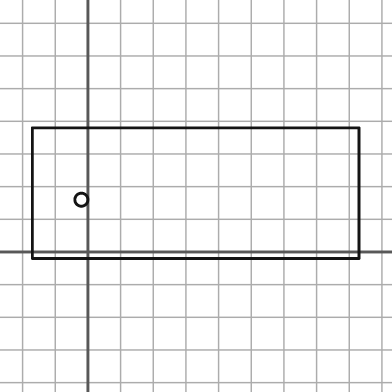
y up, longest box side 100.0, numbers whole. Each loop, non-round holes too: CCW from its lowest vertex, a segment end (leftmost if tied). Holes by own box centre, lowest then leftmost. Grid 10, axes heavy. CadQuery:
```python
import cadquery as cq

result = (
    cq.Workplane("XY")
    .moveTo(-17.0, -2.0)
    .lineTo(83.0, -2.0)
    .lineTo(83.0, 38.0)
    .lineTo(-17.0, 38.0)
    .close()
    .moveTo(-2.0, 16.0)
    .circle(2.0)
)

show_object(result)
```